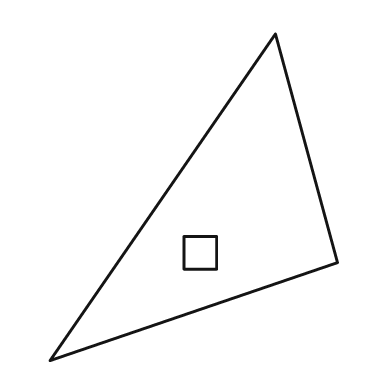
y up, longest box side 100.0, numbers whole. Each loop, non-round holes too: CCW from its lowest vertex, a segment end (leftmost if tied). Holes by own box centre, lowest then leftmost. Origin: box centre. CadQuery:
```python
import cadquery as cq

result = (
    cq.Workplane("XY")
    .moveTo(-44.0, -50.0)
    .lineTo(44.0, -20.0)
    .lineTo(25.0, 50.0)
    .close()
    .moveTo(-3.0, -22.0)
    .lineTo(7.0, -22.0)
    .lineTo(7.0, -12.0)
    .lineTo(-3.0, -12.0)
    .close()
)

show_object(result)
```